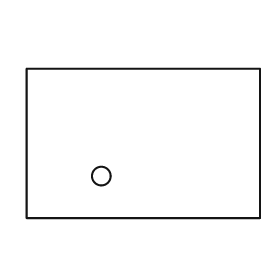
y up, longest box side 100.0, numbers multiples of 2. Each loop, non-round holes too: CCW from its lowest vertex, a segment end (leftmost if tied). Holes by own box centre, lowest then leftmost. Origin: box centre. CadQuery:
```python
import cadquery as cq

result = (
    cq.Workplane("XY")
    .moveTo(-50.0, -32.0)
    .lineTo(50.0, -32.0)
    .lineTo(50.0, 32.0)
    .lineTo(-50.0, 32.0)
    .close()
    .moveTo(-18.0, -14.0)
    .circle(4.0)
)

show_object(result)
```